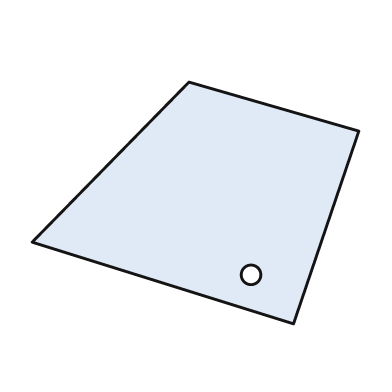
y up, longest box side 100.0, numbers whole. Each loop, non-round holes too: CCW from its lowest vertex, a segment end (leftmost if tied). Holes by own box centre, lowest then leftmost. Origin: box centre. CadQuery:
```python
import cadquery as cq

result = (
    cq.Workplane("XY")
    .moveTo(30.0, -37.0)
    .lineTo(50.0, 22.0)
    .lineTo(-2.0, 37.0)
    .lineTo(-50.0, -12.0)
    .close()
    .moveTo(17.0, -22.0)
    .circle(3.0)
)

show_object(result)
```